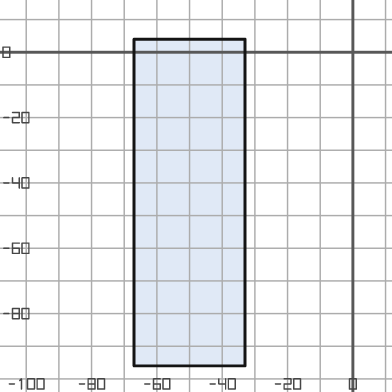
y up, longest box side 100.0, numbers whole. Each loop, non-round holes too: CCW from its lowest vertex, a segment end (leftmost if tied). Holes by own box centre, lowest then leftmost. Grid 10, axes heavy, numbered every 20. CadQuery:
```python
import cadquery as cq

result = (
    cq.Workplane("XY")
    .moveTo(-67.0, -96.0)
    .lineTo(-33.0, -96.0)
    .lineTo(-33.0, 4.0)
    .lineTo(-67.0, 4.0)
    .close()
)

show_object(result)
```